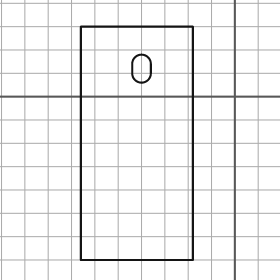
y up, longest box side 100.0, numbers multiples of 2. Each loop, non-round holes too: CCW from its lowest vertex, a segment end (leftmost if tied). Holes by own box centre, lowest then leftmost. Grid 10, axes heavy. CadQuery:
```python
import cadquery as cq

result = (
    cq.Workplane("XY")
    .moveTo(-66.0, -70.0)
    .lineTo(-18.0, -70.0)
    .lineTo(-18.0, 30.0)
    .lineTo(-66.0, 30.0)
    .close()
    .moveTo(-44.0, 10.0)
    .threePointArc((-40.0, 6.0), (-36.0, 10.0))
    .lineTo(-36.0, 14.0)
    .threePointArc((-40.0, 18.0), (-44.0, 14.0))
    .close()
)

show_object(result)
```